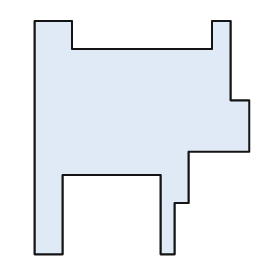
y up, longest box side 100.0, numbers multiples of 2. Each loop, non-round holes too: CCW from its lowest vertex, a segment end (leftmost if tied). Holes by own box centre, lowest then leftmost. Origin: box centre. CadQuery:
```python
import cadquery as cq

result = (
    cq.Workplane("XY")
    .moveTo(-46.0, -50.0)
    .lineTo(-34.0, -50.0)
    .lineTo(-34.0, -16.0)
    .lineTo(8.0, -16.0)
    .lineTo(8.0, -50.0)
    .lineTo(14.0, -50.0)
    .lineTo(14.0, -28.0)
    .lineTo(20.0, -28.0)
    .lineTo(20.0, -6.0)
    .lineTo(46.0, -6.0)
    .lineTo(46.0, 16.0)
    .lineTo(38.0, 16.0)
    .lineTo(38.0, 50.0)
    .lineTo(30.0, 50.0)
    .lineTo(30.0, 38.0)
    .lineTo(-30.0, 38.0)
    .lineTo(-30.0, 50.0)
    .lineTo(-46.0, 50.0)
    .close()
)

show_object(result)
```